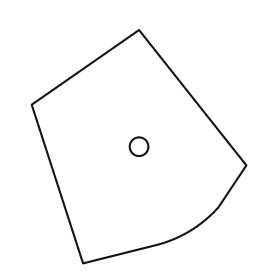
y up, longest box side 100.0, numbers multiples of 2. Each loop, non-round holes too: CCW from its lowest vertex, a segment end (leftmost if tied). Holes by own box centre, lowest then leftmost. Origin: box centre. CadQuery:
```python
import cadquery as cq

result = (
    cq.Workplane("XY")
    .moveTo(-24.0, -50.0)
    .lineTo(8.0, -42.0)
    .threePointArc((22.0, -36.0), (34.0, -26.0))
    .lineTo(46.0, -8.0)
    .lineTo(0.0, 50.0)
    .lineTo(-46.0, 18.0)
    .close()
    .moveTo(0.0, 0.0)
    .circle(4.0)
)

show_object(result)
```